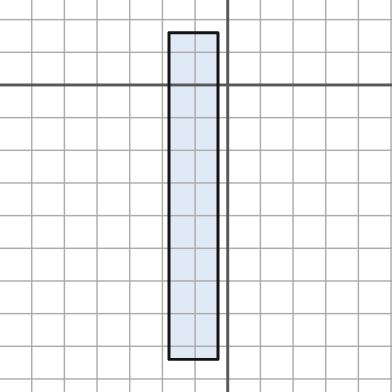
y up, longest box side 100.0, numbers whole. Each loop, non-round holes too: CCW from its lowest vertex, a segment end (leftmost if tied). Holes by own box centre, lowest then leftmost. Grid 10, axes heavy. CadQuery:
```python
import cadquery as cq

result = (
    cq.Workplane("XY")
    .moveTo(-18.0, -84.0)
    .lineTo(-3.0, -84.0)
    .lineTo(-3.0, 16.0)
    .lineTo(-18.0, 16.0)
    .close()
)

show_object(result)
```